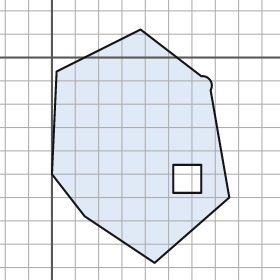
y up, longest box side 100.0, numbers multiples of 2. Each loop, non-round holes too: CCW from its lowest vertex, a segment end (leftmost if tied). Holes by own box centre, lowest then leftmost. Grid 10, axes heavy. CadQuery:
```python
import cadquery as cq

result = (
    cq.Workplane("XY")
    .moveTo(44.0, -88.0)
    .lineTo(76.0, -60.0)
    .lineTo(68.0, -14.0)
    .threePointArc((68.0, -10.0), (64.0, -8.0))
    .lineTo(38.0, 12.0)
    .lineTo(2.0, -6.0)
    .lineTo(0.0, -50.0)
    .lineTo(14.0, -68.0)
    .close()
    .moveTo(52.0, -58.0)
    .lineTo(64.0, -58.0)
    .lineTo(64.0, -46.0)
    .lineTo(52.0, -46.0)
    .close()
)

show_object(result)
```